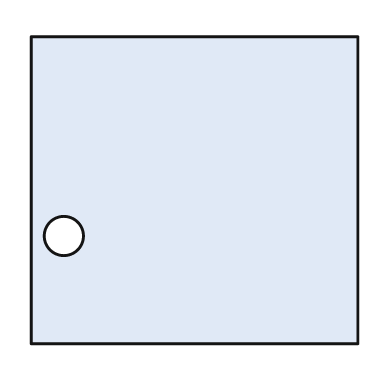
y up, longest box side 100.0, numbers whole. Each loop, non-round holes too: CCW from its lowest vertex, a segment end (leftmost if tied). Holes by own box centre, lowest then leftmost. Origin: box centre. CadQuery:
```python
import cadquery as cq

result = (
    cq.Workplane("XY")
    .moveTo(-50.0, -47.0)
    .lineTo(50.0, -47.0)
    .lineTo(50.0, 47.0)
    .lineTo(-50.0, 47.0)
    .close()
    .moveTo(-40.0, -14.0)
    .circle(6.0)
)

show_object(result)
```